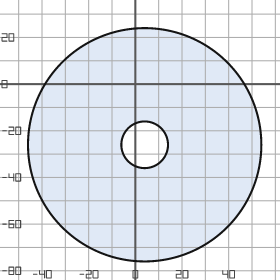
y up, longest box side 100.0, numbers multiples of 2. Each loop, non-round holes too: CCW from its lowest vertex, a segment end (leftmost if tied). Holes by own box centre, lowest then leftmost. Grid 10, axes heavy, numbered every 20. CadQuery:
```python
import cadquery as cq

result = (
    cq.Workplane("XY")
    .moveTo(4.0, -26.0)
    .circle(50.0)
    .moveTo(4.0, -26.0)
    .circle(10.0)
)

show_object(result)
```